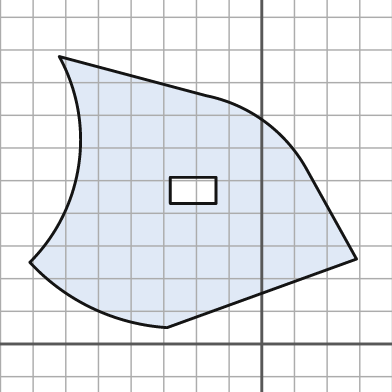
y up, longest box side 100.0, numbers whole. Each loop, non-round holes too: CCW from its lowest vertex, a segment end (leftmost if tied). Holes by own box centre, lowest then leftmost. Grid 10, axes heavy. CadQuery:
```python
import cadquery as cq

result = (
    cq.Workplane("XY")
    .moveTo(-29.0, 5.0)
    .lineTo(29.0, 26.0)
    .lineTo(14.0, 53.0)
    .threePointArc((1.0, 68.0), (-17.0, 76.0))
    .lineTo(-62.0, 88.0)
    .threePointArc((-56.0, 55.0), (-71.0, 25.0))
    .threePointArc((-52.0, 11.0), (-29.0, 5.0))
    .close()
    .moveTo(-28.0, 43.0)
    .lineTo(-14.0, 43.0)
    .lineTo(-14.0, 51.0)
    .lineTo(-28.0, 51.0)
    .close()
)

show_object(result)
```